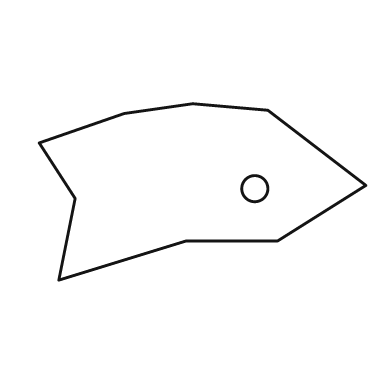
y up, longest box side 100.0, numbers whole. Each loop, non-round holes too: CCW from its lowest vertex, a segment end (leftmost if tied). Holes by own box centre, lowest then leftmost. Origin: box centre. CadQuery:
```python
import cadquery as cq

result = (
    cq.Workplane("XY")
    .moveTo(-44.0, -27.0)
    .lineTo(-5.0, -15.0)
    .lineTo(23.0, -15.0)
    .lineTo(50.0, 2.0)
    .lineTo(20.0, 25.0)
    .lineTo(-3.0, 27.0)
    .lineTo(-24.0, 24.0)
    .lineTo(-50.0, 15.0)
    .lineTo(-39.0, -2.0)
    .close()
    .moveTo(16.0, 1.0)
    .circle(4.0)
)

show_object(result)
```